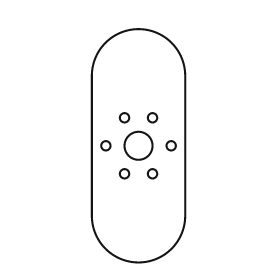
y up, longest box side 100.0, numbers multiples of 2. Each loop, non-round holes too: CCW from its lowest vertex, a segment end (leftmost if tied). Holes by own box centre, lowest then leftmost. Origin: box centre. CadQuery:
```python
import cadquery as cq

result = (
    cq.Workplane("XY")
    .moveTo(-20.0, -30.0)
    .threePointArc((0.0, -50.0), (20.0, -30.0))
    .lineTo(20.0, 30.0)
    .threePointArc((0.0, 50.0), (-20.0, 30.0))
    .close()
    .moveTo(-6.0, -12.0)
    .circle(2.0)
    .moveTo(6.0, -12.0)
    .circle(2.0)
    .moveTo(-14.0, 0.0)
    .circle(2.0)
    .moveTo(0.0, 0.0)
    .circle(6.0)
    .moveTo(14.0, 0.0)
    .circle(2.0)
    .moveTo(-6.0, 12.0)
    .circle(2.0)
    .moveTo(6.0, 12.0)
    .circle(2.0)
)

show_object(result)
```